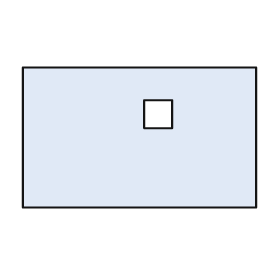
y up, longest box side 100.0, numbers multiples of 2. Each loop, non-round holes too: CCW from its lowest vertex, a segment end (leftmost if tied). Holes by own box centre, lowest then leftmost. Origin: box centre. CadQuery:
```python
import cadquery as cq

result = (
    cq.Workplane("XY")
    .moveTo(-50.0, -30.0)
    .lineTo(50.0, -30.0)
    .lineTo(50.0, 30.0)
    .lineTo(-50.0, 30.0)
    .close()
    .moveTo(2.0, 4.0)
    .lineTo(14.0, 4.0)
    .lineTo(14.0, 16.0)
    .lineTo(2.0, 16.0)
    .close()
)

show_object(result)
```